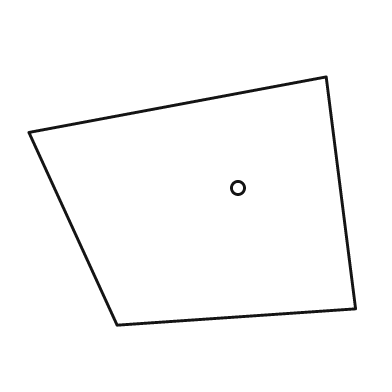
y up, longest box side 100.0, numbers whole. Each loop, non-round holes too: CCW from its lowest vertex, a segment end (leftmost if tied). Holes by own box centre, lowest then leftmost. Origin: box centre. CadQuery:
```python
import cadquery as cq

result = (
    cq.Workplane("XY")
    .moveTo(-23.0, -38.0)
    .lineTo(50.0, -33.0)
    .lineTo(41.0, 38.0)
    .lineTo(-50.0, 21.0)
    .close()
    .moveTo(14.0, 4.0)
    .circle(2.0)
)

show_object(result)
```